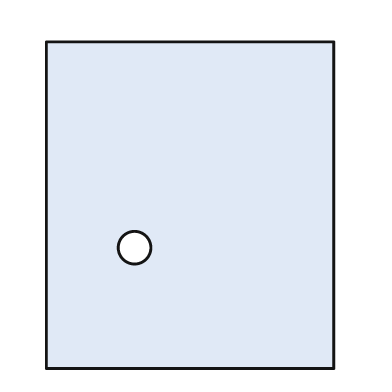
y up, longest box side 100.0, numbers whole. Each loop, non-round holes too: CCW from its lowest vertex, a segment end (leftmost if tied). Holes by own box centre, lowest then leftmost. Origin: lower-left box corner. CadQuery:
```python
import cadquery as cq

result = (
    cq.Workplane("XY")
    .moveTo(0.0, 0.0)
    .lineTo(88.0, 0.0)
    .lineTo(88.0, 100.0)
    .lineTo(0.0, 100.0)
    .close()
    .moveTo(27.0, 37.0)
    .circle(5.0)
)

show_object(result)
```